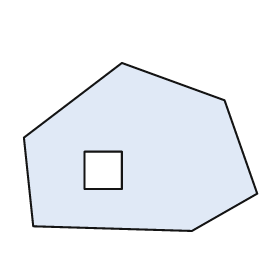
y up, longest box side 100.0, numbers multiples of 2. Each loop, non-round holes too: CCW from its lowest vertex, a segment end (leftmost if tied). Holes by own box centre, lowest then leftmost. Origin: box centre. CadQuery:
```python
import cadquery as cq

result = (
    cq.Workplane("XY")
    .moveTo(22.0, -36.0)
    .lineTo(50.0, -20.0)
    .lineTo(36.0, 20.0)
    .lineTo(-8.0, 36.0)
    .lineTo(-50.0, 4.0)
    .lineTo(-46.0, -34.0)
    .close()
    .moveTo(-24.0, -18.0)
    .lineTo(-8.0, -18.0)
    .lineTo(-8.0, -2.0)
    .lineTo(-24.0, -2.0)
    .close()
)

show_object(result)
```